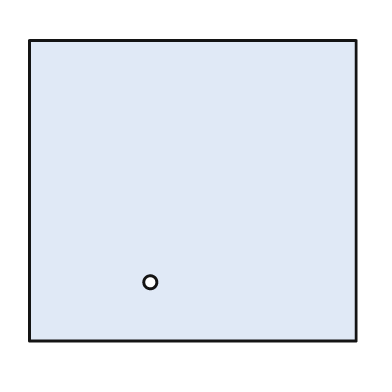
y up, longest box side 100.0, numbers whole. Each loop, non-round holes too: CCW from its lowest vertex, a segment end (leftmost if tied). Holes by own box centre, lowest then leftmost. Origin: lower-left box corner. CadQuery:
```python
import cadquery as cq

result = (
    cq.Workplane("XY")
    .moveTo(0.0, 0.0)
    .lineTo(100.0, 0.0)
    .lineTo(100.0, 92.0)
    .lineTo(0.0, 92.0)
    .close()
    .moveTo(37.0, 18.0)
    .circle(2.0)
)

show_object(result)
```